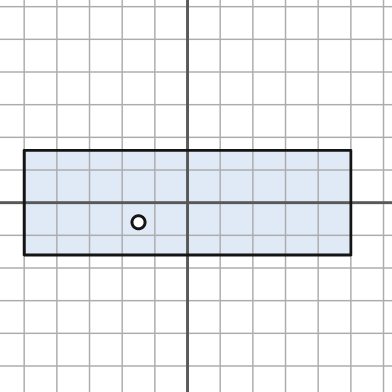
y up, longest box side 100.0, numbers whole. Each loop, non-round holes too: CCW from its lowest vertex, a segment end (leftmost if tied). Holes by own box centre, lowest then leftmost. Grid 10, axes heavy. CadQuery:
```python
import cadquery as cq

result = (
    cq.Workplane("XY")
    .moveTo(-50.0, -16.0)
    .lineTo(50.0, -16.0)
    .lineTo(50.0, 16.0)
    .lineTo(-50.0, 16.0)
    .close()
    .moveTo(-15.0, -6.0)
    .circle(2.0)
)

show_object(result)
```